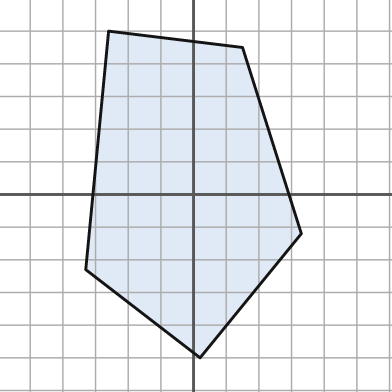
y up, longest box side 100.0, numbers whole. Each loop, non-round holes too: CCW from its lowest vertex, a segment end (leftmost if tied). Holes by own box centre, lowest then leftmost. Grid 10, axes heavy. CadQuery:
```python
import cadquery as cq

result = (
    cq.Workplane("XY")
    .moveTo(2.0, -50.0)
    .lineTo(33.0, -12.0)
    .lineTo(15.0, 45.0)
    .lineTo(-26.0, 50.0)
    .lineTo(-33.0, -23.0)
    .close()
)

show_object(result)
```